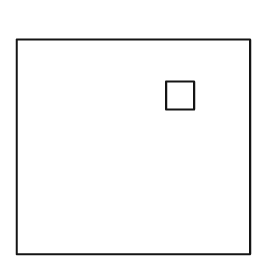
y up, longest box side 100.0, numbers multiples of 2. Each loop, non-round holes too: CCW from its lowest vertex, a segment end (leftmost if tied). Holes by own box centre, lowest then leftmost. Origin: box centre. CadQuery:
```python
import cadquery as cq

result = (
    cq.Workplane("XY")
    .moveTo(-50.0, -46.0)
    .lineTo(50.0, -46.0)
    .lineTo(50.0, 46.0)
    .lineTo(-50.0, 46.0)
    .close()
    .moveTo(14.0, 16.0)
    .lineTo(26.0, 16.0)
    .lineTo(26.0, 28.0)
    .lineTo(14.0, 28.0)
    .close()
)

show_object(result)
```